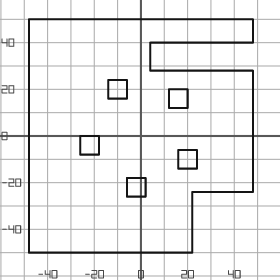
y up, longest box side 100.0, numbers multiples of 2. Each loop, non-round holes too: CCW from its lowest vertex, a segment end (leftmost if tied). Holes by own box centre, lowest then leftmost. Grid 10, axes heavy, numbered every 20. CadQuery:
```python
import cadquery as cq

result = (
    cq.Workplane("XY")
    .moveTo(-48.0, -50.0)
    .lineTo(22.0, -50.0)
    .lineTo(22.0, -24.0)
    .lineTo(48.0, -24.0)
    .lineTo(48.0, 28.0)
    .lineTo(4.0, 28.0)
    .lineTo(4.0, 40.0)
    .lineTo(48.0, 40.0)
    .lineTo(48.0, 50.0)
    .lineTo(-48.0, 50.0)
    .close()
    .moveTo(-6.0, -26.0)
    .lineTo(2.0, -26.0)
    .lineTo(2.0, -18.0)
    .lineTo(-6.0, -18.0)
    .close()
    .moveTo(16.0, -14.0)
    .lineTo(24.0, -14.0)
    .lineTo(24.0, -6.0)
    .lineTo(16.0, -6.0)
    .close()
    .moveTo(-26.0, -8.0)
    .lineTo(-18.0, -8.0)
    .lineTo(-18.0, 0.0)
    .lineTo(-26.0, 0.0)
    .close()
    .moveTo(12.0, 12.0)
    .lineTo(20.0, 12.0)
    .lineTo(20.0, 20.0)
    .lineTo(12.0, 20.0)
    .close()
    .moveTo(-14.0, 16.0)
    .lineTo(-6.0, 16.0)
    .lineTo(-6.0, 24.0)
    .lineTo(-14.0, 24.0)
    .close()
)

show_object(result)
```